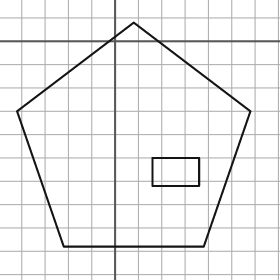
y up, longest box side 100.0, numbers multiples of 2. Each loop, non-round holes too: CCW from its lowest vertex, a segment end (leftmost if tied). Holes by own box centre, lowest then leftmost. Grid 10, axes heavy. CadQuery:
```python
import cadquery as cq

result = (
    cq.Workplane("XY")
    .moveTo(-22.0, -88.0)
    .lineTo(38.0, -88.0)
    .lineTo(58.0, -30.0)
    .lineTo(8.0, 8.0)
    .lineTo(-42.0, -30.0)
    .close()
    .moveTo(16.0, -62.0)
    .lineTo(36.0, -62.0)
    .lineTo(36.0, -50.0)
    .lineTo(16.0, -50.0)
    .close()
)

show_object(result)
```